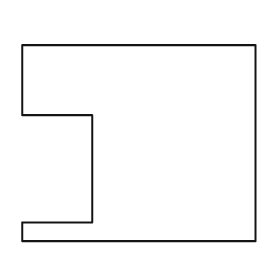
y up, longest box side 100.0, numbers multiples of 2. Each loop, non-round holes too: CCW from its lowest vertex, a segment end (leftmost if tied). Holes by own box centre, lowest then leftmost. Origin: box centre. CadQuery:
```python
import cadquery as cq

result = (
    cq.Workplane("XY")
    .moveTo(-50.0, -42.0)
    .lineTo(50.0, -42.0)
    .lineTo(50.0, 42.0)
    .lineTo(-50.0, 42.0)
    .lineTo(-50.0, 12.0)
    .lineTo(-20.0, 12.0)
    .lineTo(-20.0, -34.0)
    .lineTo(-50.0, -34.0)
    .close()
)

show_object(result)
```